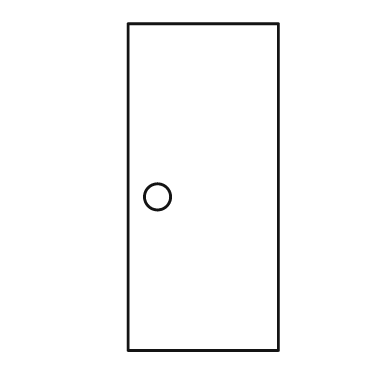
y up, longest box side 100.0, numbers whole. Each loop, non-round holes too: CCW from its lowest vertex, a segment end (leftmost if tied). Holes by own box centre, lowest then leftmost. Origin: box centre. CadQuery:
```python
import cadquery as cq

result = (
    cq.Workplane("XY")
    .moveTo(-23.0, -50.0)
    .lineTo(23.0, -50.0)
    .lineTo(23.0, 50.0)
    .lineTo(-23.0, 50.0)
    .close()
    .moveTo(-14.0, -3.0)
    .circle(4.0)
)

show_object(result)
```